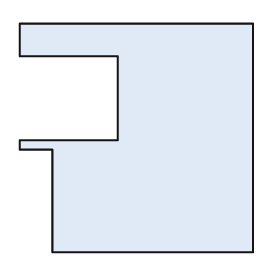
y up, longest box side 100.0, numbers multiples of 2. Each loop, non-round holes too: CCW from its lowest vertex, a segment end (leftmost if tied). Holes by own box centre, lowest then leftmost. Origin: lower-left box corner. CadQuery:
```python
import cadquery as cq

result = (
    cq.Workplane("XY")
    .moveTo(14.0, 0.0)
    .lineTo(100.0, 0.0)
    .lineTo(100.0, 98.0)
    .lineTo(0.0, 98.0)
    .lineTo(0.0, 84.0)
    .lineTo(42.0, 84.0)
    .lineTo(42.0, 48.0)
    .lineTo(0.0, 48.0)
    .lineTo(0.0, 44.0)
    .lineTo(14.0, 44.0)
    .close()
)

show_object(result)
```